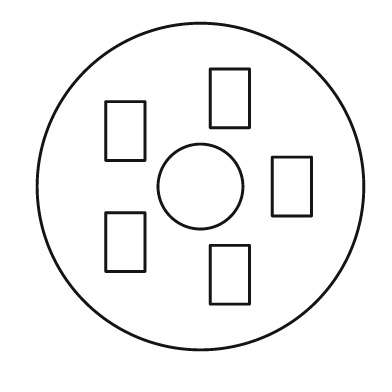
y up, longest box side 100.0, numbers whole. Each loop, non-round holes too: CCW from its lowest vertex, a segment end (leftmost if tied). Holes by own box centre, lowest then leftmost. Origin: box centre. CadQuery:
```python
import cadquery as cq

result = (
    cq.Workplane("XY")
    .moveTo(0.0, 0.0)
    .circle(50.0)
    .moveTo(3.0, -36.0)
    .lineTo(15.0, -36.0)
    .lineTo(15.0, -18.0)
    .lineTo(3.0, -18.0)
    .close()
    .moveTo(-29.0, -26.0)
    .lineTo(-17.0, -26.0)
    .lineTo(-17.0, -8.0)
    .lineTo(-29.0, -8.0)
    .close()
    .moveTo(0.0, 0.0)
    .circle(13.0)
    .moveTo(22.0, -9.0)
    .lineTo(34.0, -9.0)
    .lineTo(34.0, 9.0)
    .lineTo(22.0, 9.0)
    .close()
    .moveTo(-29.0, 8.0)
    .lineTo(-17.0, 8.0)
    .lineTo(-17.0, 26.0)
    .lineTo(-29.0, 26.0)
    .close()
    .moveTo(3.0, 18.0)
    .lineTo(15.0, 18.0)
    .lineTo(15.0, 36.0)
    .lineTo(3.0, 36.0)
    .close()
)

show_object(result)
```